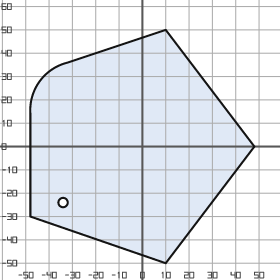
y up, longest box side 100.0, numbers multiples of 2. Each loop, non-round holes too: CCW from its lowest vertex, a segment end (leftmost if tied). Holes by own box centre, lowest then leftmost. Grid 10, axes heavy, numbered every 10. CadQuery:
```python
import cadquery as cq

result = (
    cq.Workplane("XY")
    .moveTo(10.0, -50.0)
    .lineTo(48.0, 0.0)
    .lineTo(10.0, 50.0)
    .lineTo(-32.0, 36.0)
    .threePointArc((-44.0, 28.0), (-48.0, 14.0))
    .lineTo(-48.0, -30.0)
    .close()
    .moveTo(-34.0, -24.0)
    .circle(2.0)
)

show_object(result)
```